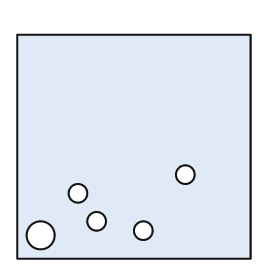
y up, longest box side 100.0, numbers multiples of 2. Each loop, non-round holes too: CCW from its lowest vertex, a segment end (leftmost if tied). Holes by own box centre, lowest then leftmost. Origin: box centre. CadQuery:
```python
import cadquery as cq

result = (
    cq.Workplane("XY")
    .moveTo(-50.0, -48.0)
    .lineTo(50.0, -48.0)
    .lineTo(50.0, 48.0)
    .lineTo(-50.0, 48.0)
    .close()
    .moveTo(-40.0, -38.0)
    .circle(6.0)
    .moveTo(4.0, -36.0)
    .circle(4.0)
    .moveTo(-16.0, -32.0)
    .circle(4.0)
    .moveTo(-24.0, -20.0)
    .circle(4.0)
    .moveTo(22.0, -12.0)
    .circle(4.0)
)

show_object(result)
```